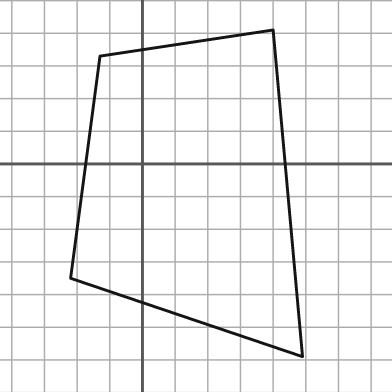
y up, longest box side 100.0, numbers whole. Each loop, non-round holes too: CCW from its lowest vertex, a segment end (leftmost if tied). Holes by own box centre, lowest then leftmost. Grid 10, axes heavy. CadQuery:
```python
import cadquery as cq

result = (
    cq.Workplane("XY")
    .moveTo(49.0, -59.0)
    .lineTo(40.0, 41.0)
    .lineTo(-13.0, 33.0)
    .lineTo(-22.0, -35.0)
    .close()
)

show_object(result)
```